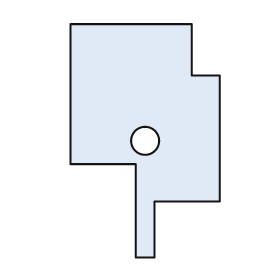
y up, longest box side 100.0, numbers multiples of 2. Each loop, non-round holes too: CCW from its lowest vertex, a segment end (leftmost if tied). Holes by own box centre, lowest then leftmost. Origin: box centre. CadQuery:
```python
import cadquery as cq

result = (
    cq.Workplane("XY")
    .moveTo(-4.0, -50.0)
    .lineTo(4.0, -50.0)
    .lineTo(4.0, -26.0)
    .lineTo(32.0, -26.0)
    .lineTo(32.0, 28.0)
    .lineTo(20.0, 28.0)
    .lineTo(20.0, 50.0)
    .lineTo(-32.0, 50.0)
    .lineTo(-32.0, -10.0)
    .lineTo(-4.0, -10.0)
    .close()
    .moveTo(0.0, 0.0)
    .circle(6.0)
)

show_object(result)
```